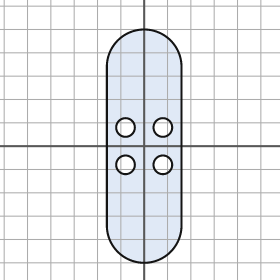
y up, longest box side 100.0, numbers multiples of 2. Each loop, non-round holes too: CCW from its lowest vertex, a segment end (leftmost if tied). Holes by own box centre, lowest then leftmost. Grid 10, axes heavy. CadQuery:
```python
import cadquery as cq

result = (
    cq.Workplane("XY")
    .moveTo(-16.0, -34.0)
    .threePointArc((0.0, -50.0), (16.0, -34.0))
    .lineTo(16.0, 34.0)
    .threePointArc((0.0, 50.0), (-16.0, 34.0))
    .close()
    .moveTo(-8.0, -8.0)
    .circle(4.0)
    .moveTo(8.0, -8.0)
    .circle(4.0)
    .moveTo(-8.0, 8.0)
    .circle(4.0)
    .moveTo(8.0, 8.0)
    .circle(4.0)
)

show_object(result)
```